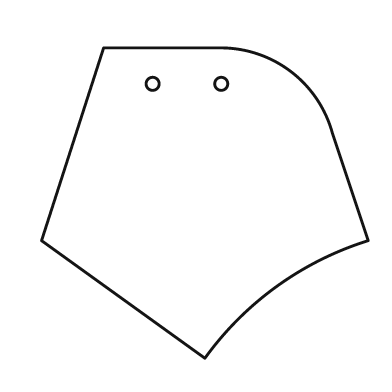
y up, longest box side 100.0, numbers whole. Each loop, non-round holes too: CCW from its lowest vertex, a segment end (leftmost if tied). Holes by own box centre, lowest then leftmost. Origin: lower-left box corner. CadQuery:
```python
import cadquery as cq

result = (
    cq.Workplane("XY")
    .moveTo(50.0, 0.0)
    .threePointArc((72.0, 22.0), (100.0, 36.0))
    .lineTo(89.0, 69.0)
    .threePointArc((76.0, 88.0), (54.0, 95.0))
    .lineTo(19.0, 95.0)
    .lineTo(0.0, 36.0)
    .close()
    .moveTo(34.0, 84.0)
    .circle(2.0)
    .moveTo(55.0, 84.0)
    .circle(2.0)
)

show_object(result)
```